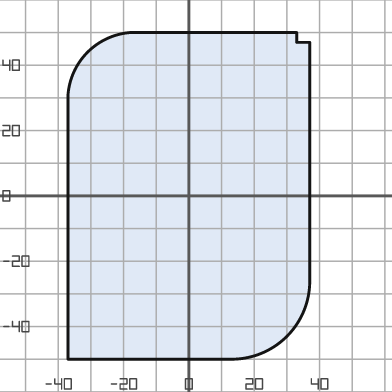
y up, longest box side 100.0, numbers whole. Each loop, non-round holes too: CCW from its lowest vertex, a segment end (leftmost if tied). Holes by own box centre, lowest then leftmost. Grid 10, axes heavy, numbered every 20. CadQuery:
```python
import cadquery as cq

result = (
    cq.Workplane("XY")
    .moveTo(-37.0, -50.0)
    .lineTo(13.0, -50.0)
    .threePointArc((30.0, -43.0), (37.0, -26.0))
    .lineTo(37.0, 47.0)
    .lineTo(33.0, 47.0)
    .lineTo(33.0, 50.0)
    .lineTo(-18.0, 50.0)
    .threePointArc((-31.0, 44.0), (-37.0, 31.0))
    .close()
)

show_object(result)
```